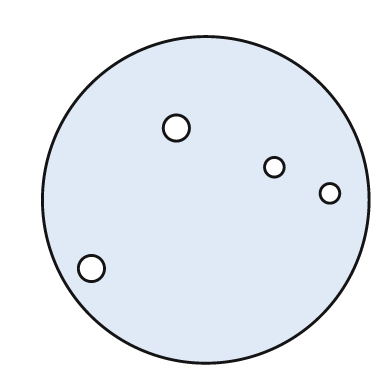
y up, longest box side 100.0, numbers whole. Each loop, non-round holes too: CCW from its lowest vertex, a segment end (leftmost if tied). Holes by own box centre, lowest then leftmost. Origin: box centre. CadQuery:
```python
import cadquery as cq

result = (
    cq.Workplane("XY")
    .moveTo(0.0, 0.0)
    .circle(50.0)
    .moveTo(-35.0, -21.0)
    .circle(4.0)
    .moveTo(38.0, 2.0)
    .circle(3.0)
    .moveTo(21.0, 10.0)
    .circle(3.0)
    .moveTo(-9.0, 22.0)
    .circle(4.0)
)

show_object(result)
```